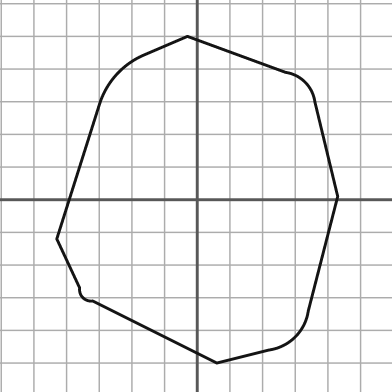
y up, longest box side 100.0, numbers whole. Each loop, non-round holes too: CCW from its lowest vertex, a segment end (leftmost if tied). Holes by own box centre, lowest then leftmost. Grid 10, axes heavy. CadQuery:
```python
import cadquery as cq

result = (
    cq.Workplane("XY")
    .moveTo(6.0, -50.0)
    .lineTo(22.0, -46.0)
    .threePointArc((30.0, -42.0), (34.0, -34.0))
    .lineTo(43.0, 1.0)
    .lineTo(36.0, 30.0)
    .threePointArc((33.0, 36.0), (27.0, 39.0))
    .lineTo(-3.0, 50.0)
    .lineTo(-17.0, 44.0)
    .threePointArc((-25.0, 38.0), (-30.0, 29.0))
    .lineTo(-43.0, -12.0)
    .lineTo(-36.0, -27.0)
    .threePointArc((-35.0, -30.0), (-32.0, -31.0))
    .close()
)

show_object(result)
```